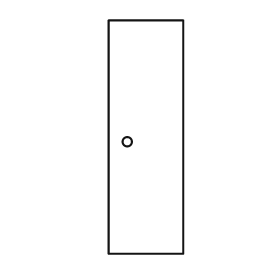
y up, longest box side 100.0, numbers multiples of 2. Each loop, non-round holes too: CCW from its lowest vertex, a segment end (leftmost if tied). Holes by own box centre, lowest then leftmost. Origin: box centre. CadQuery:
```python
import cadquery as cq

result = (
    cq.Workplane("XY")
    .moveTo(-16.0, -50.0)
    .lineTo(16.0, -50.0)
    .lineTo(16.0, 50.0)
    .lineTo(-16.0, 50.0)
    .close()
    .moveTo(-8.0, -2.0)
    .circle(2.0)
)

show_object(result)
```